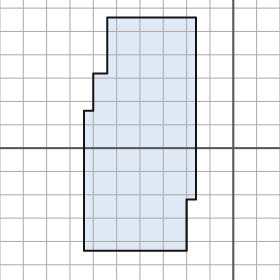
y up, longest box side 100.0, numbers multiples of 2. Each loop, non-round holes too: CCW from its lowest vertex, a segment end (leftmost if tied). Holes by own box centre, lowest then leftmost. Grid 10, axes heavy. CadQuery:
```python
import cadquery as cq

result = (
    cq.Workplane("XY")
    .moveTo(-64.0, -44.0)
    .lineTo(-20.0, -44.0)
    .lineTo(-20.0, -22.0)
    .lineTo(-16.0, -22.0)
    .lineTo(-16.0, 56.0)
    .lineTo(-54.0, 56.0)
    .lineTo(-54.0, 32.0)
    .lineTo(-60.0, 32.0)
    .lineTo(-60.0, 16.0)
    .lineTo(-64.0, 16.0)
    .close()
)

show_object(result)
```